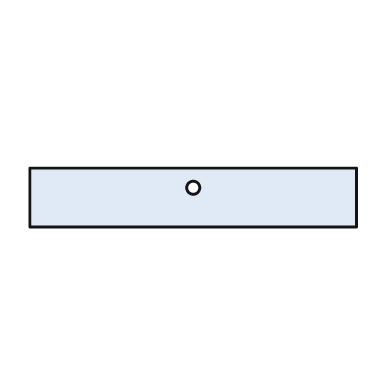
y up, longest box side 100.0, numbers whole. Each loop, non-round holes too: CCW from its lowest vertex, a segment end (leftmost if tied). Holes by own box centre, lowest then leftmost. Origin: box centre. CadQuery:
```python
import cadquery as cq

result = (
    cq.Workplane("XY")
    .moveTo(-50.0, -9.0)
    .lineTo(50.0, -9.0)
    .lineTo(50.0, 9.0)
    .lineTo(-50.0, 9.0)
    .close()
    .moveTo(0.0, 3.0)
    .circle(2.0)
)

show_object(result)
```